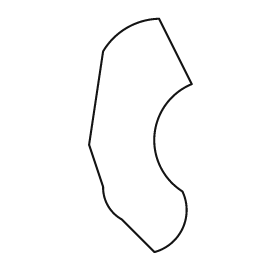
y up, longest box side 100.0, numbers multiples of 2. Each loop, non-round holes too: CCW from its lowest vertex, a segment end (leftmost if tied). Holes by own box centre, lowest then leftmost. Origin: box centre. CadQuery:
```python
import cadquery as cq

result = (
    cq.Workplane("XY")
    .moveTo(6.0, -50.0)
    .threePointArc((18.0, -40.0), (18.0, -24.0))
    .threePointArc((6.0, 0.0), (22.0, 22.0))
    .lineTo(8.0, 50.0)
    .threePointArc((-6.0, 46.0), (-16.0, 36.0))
    .lineTo(-22.0, -4.0)
    .lineTo(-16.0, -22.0)
    .threePointArc((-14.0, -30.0), (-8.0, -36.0))
    .close()
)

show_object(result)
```